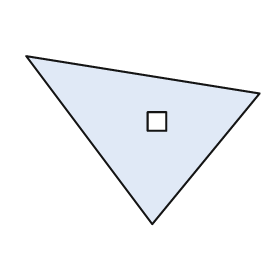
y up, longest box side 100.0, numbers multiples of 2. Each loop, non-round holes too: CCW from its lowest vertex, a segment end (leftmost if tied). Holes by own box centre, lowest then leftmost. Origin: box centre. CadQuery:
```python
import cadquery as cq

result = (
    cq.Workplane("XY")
    .moveTo(4.0, -36.0)
    .lineTo(50.0, 20.0)
    .lineTo(-50.0, 36.0)
    .close()
    .moveTo(2.0, 4.0)
    .lineTo(10.0, 4.0)
    .lineTo(10.0, 12.0)
    .lineTo(2.0, 12.0)
    .close()
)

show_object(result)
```